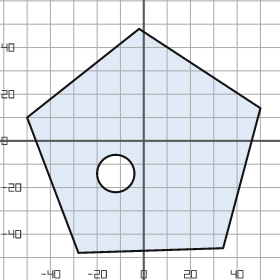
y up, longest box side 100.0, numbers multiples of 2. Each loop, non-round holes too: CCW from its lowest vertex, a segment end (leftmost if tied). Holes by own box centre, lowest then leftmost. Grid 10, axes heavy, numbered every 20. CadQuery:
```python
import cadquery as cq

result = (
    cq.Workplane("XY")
    .moveTo(-28.0, -48.0)
    .lineTo(34.0, -46.0)
    .lineTo(50.0, 14.0)
    .lineTo(-2.0, 48.0)
    .lineTo(-50.0, 10.0)
    .close()
    .moveTo(-12.0, -14.0)
    .circle(8.0)
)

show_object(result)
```